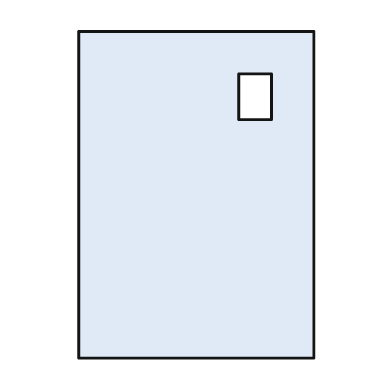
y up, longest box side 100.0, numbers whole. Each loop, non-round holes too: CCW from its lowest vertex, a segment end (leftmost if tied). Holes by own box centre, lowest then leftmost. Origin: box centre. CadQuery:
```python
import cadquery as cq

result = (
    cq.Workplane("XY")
    .moveTo(-36.0, -50.0)
    .lineTo(36.0, -50.0)
    .lineTo(36.0, 50.0)
    .lineTo(-36.0, 50.0)
    .close()
    .moveTo(13.0, 23.0)
    .lineTo(23.0, 23.0)
    .lineTo(23.0, 37.0)
    .lineTo(13.0, 37.0)
    .close()
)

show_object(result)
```